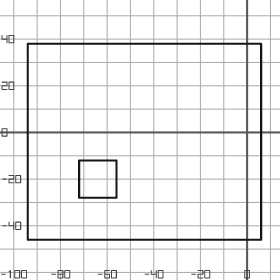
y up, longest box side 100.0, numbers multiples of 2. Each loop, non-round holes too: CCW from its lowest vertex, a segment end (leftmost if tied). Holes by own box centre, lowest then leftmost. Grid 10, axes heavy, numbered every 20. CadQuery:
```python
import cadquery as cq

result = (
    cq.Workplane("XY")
    .moveTo(-94.0, -46.0)
    .lineTo(6.0, -46.0)
    .lineTo(6.0, 38.0)
    .lineTo(-94.0, 38.0)
    .close()
    .moveTo(-72.0, -28.0)
    .lineTo(-56.0, -28.0)
    .lineTo(-56.0, -12.0)
    .lineTo(-72.0, -12.0)
    .close()
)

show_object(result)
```